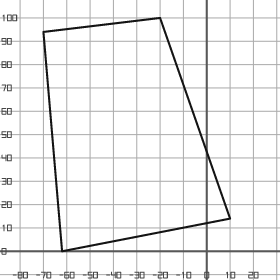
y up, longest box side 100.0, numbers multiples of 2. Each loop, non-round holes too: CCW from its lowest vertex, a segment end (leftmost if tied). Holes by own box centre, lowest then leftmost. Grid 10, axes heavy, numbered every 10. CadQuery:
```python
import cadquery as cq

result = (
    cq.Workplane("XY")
    .moveTo(-62.0, 0.0)
    .lineTo(10.0, 14.0)
    .lineTo(-20.0, 100.0)
    .lineTo(-70.0, 94.0)
    .close()
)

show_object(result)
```